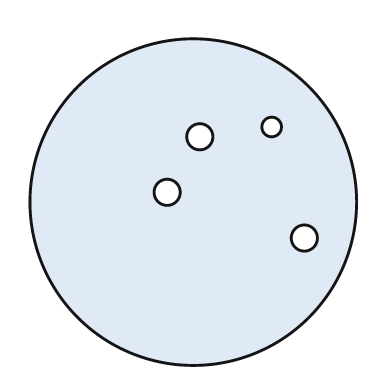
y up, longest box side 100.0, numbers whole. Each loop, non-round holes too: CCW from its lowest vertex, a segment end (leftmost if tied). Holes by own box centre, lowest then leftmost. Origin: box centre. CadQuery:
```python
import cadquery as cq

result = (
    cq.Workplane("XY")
    .moveTo(0.0, 0.0)
    .circle(50.0)
    .moveTo(34.0, -11.0)
    .circle(4.0)
    .moveTo(-8.0, 3.0)
    .circle(4.0)
    .moveTo(2.0, 20.0)
    .circle(4.0)
    .moveTo(24.0, 23.0)
    .circle(3.0)
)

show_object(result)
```